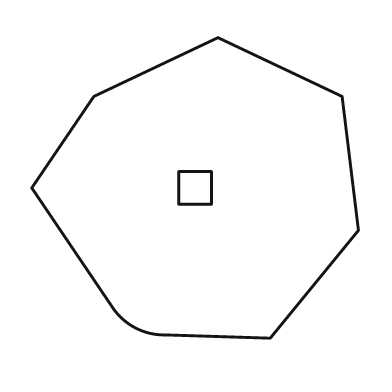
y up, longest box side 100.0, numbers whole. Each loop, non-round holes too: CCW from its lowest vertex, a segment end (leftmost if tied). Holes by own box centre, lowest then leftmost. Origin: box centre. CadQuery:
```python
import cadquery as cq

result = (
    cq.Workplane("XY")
    .moveTo(23.0, -46.0)
    .lineTo(50.0, -13.0)
    .lineTo(45.0, 28.0)
    .lineTo(7.0, 46.0)
    .lineTo(-31.0, 28.0)
    .lineTo(-50.0, 0.0)
    .lineTo(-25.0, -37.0)
    .threePointArc((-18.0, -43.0), (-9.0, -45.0))
    .close()
    .moveTo(-5.0, -5.0)
    .lineTo(5.0, -5.0)
    .lineTo(5.0, 5.0)
    .lineTo(-5.0, 5.0)
    .close()
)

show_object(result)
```